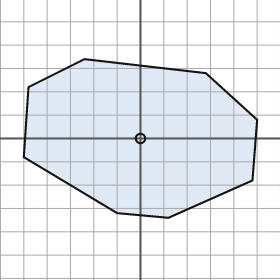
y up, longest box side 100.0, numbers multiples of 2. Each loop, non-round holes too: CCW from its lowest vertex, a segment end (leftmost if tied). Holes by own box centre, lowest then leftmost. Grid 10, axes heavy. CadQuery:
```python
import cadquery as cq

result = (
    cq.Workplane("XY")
    .moveTo(12.0, -34.0)
    .lineTo(48.0, -18.0)
    .lineTo(50.0, 8.0)
    .lineTo(28.0, 28.0)
    .lineTo(-24.0, 34.0)
    .lineTo(-48.0, 22.0)
    .lineTo(-50.0, -8.0)
    .lineTo(-10.0, -32.0)
    .close()
    .moveTo(0.0, 0.0)
    .circle(2.0)
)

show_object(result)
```